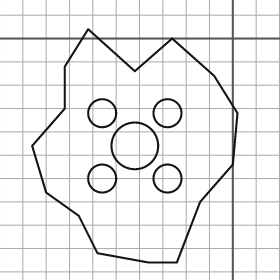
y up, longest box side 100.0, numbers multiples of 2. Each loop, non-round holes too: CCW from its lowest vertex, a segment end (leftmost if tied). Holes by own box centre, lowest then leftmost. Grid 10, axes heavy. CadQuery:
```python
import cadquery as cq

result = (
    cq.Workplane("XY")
    .moveTo(-36.0, -96.0)
    .lineTo(-24.0, -96.0)
    .lineTo(-14.0, -70.0)
    .lineTo(0.0, -54.0)
    .lineTo(2.0, -32.0)
    .lineTo(-8.0, -16.0)
    .lineTo(-26.0, 0.0)
    .lineTo(-42.0, -14.0)
    .lineTo(-62.0, 4.0)
    .lineTo(-72.0, -12.0)
    .lineTo(-72.0, -30.0)
    .lineTo(-86.0, -46.0)
    .lineTo(-80.0, -66.0)
    .lineTo(-66.0, -76.0)
    .lineTo(-58.0, -92.0)
    .close()
    .moveTo(-56.0, -60.0)
    .circle(6.0)
    .moveTo(-28.0, -60.0)
    .circle(6.0)
    .moveTo(-42.0, -46.0)
    .circle(10.0)
    .moveTo(-56.0, -32.0)
    .circle(6.0)
    .moveTo(-28.0, -32.0)
    .circle(6.0)
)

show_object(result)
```